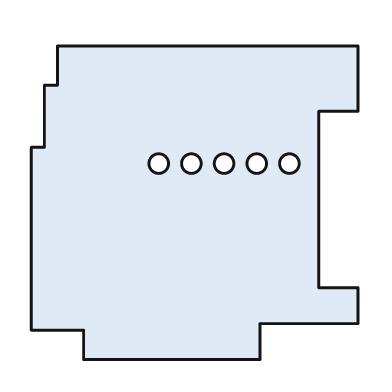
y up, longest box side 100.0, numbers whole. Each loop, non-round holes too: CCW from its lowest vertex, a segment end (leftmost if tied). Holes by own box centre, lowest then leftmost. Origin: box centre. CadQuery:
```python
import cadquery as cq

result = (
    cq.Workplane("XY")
    .moveTo(-34.0, -48.0)
    .lineTo(20.0, -48.0)
    .lineTo(20.0, -37.0)
    .lineTo(50.0, -37.0)
    .lineTo(50.0, -26.0)
    .lineTo(38.0, -26.0)
    .lineTo(38.0, 28.0)
    .lineTo(50.0, 28.0)
    .lineTo(50.0, 48.0)
    .lineTo(-42.0, 48.0)
    .lineTo(-42.0, 36.0)
    .lineTo(-46.0, 36.0)
    .lineTo(-46.0, 17.0)
    .lineTo(-50.0, 17.0)
    .lineTo(-50.0, -39.0)
    .lineTo(-34.0, -39.0)
    .close()
    .moveTo(-11.0, 12.0)
    .circle(3.0)
    .moveTo(-1.0, 12.0)
    .circle(3.0)
    .moveTo(9.0, 12.0)
    .circle(3.0)
    .moveTo(19.0, 12.0)
    .circle(3.0)
    .moveTo(29.0, 12.0)
    .circle(3.0)
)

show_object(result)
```